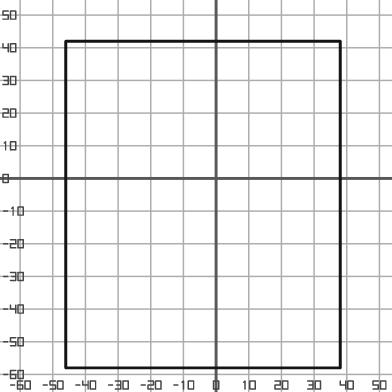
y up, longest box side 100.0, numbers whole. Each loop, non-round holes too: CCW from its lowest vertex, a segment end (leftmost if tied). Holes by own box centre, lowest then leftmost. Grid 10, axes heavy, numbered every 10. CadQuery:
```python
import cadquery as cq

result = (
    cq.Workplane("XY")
    .moveTo(-46.0, -58.0)
    .lineTo(38.0, -58.0)
    .lineTo(38.0, 42.0)
    .lineTo(-46.0, 42.0)
    .close()
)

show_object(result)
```